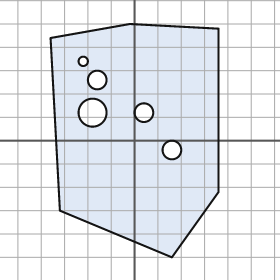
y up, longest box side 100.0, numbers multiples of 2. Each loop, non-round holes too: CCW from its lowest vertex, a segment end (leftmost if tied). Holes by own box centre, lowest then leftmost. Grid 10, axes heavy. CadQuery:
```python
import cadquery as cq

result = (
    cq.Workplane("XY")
    .moveTo(16.0, -50.0)
    .lineTo(36.0, -22.0)
    .lineTo(36.0, 48.0)
    .lineTo(-2.0, 50.0)
    .lineTo(-36.0, 44.0)
    .lineTo(-32.0, -30.0)
    .close()
    .moveTo(16.0, -4.0)
    .circle(4.0)
    .moveTo(-18.0, 12.0)
    .circle(6.0)
    .moveTo(4.0, 12.0)
    .circle(4.0)
    .moveTo(-16.0, 26.0)
    .circle(4.0)
    .moveTo(-22.0, 34.0)
    .circle(2.0)
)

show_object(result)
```